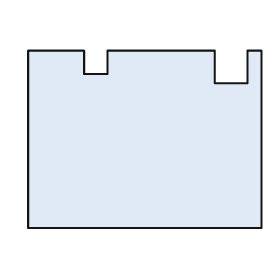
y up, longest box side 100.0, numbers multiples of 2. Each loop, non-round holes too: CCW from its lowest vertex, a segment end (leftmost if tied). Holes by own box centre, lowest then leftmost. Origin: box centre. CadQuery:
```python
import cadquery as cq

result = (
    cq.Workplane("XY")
    .moveTo(-50.0, -38.0)
    .lineTo(50.0, -38.0)
    .lineTo(50.0, 38.0)
    .lineTo(44.0, 38.0)
    .lineTo(44.0, 24.0)
    .lineTo(30.0, 24.0)
    .lineTo(30.0, 38.0)
    .lineTo(-16.0, 38.0)
    .lineTo(-16.0, 28.0)
    .lineTo(-26.0, 28.0)
    .lineTo(-26.0, 38.0)
    .lineTo(-50.0, 38.0)
    .close()
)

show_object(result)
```